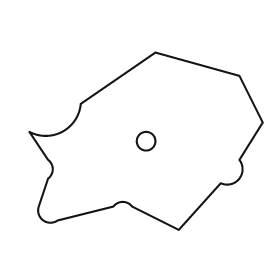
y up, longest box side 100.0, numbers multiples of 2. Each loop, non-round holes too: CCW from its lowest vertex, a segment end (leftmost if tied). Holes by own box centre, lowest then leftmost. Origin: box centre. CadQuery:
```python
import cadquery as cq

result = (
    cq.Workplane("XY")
    .moveTo(14.0, -38.0)
    .lineTo(32.0, -18.0)
    .threePointArc((40.0, -16.0), (40.0, -8.0))
    .lineTo(50.0, 8.0)
    .lineTo(40.0, 28.0)
    .lineTo(4.0, 38.0)
    .lineTo(-28.0, 16.0)
    .threePointArc((-36.0, 4.0), (-50.0, 4.0))
    .lineTo(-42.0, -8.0)
    .threePointArc((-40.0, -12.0), (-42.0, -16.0))
    .lineTo(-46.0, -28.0)
    .threePointArc((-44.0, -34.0), (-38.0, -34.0))
    .lineTo(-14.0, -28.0)
    .threePointArc((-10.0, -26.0), (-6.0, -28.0))
    .close()
    .moveTo(0.0, 0.0)
    .circle(4.0)
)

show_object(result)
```